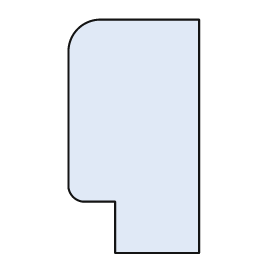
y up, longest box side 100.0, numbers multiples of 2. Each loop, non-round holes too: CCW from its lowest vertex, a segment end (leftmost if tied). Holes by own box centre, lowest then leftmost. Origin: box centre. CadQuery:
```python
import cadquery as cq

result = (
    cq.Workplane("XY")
    .moveTo(-8.0, -50.0)
    .lineTo(28.0, -50.0)
    .lineTo(28.0, 50.0)
    .lineTo(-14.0, 50.0)
    .threePointArc((-24.0, 46.0), (-28.0, 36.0))
    .lineTo(-28.0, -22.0)
    .threePointArc((-26.0, -26.0), (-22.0, -28.0))
    .lineTo(-8.0, -28.0)
    .close()
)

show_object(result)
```